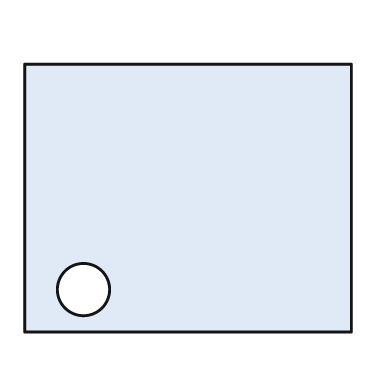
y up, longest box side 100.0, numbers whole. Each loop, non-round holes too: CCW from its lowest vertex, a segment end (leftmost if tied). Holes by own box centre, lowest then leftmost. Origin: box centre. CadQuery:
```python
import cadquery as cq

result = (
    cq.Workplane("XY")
    .moveTo(-50.0, -41.0)
    .lineTo(50.0, -41.0)
    .lineTo(50.0, 41.0)
    .lineTo(-50.0, 41.0)
    .close()
    .moveTo(-32.0, -28.0)
    .circle(8.0)
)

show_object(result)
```